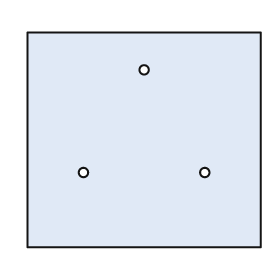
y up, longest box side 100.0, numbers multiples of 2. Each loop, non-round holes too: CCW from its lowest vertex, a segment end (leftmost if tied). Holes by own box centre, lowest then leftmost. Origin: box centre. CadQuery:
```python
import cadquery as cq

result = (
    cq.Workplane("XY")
    .moveTo(-50.0, -46.0)
    .lineTo(50.0, -46.0)
    .lineTo(50.0, 46.0)
    .lineTo(-50.0, 46.0)
    .close()
    .moveTo(-26.0, -14.0)
    .circle(2.0)
    .moveTo(26.0, -14.0)
    .circle(2.0)
    .moveTo(0.0, 30.0)
    .circle(2.0)
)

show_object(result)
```